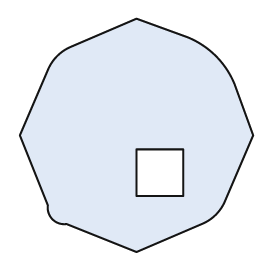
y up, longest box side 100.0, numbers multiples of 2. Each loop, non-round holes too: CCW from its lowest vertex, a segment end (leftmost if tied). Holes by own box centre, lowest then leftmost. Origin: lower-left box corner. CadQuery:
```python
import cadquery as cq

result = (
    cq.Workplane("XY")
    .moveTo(50.0, 0.0)
    .lineTo(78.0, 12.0)
    .threePointArc((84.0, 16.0), (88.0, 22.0))
    .lineTo(100.0, 50.0)
    .lineTo(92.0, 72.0)
    .threePointArc((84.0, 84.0), (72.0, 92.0))
    .lineTo(50.0, 100.0)
    .lineTo(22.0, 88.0)
    .threePointArc((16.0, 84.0), (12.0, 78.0))
    .lineTo(0.0, 50.0)
    .lineTo(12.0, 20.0)
    .threePointArc((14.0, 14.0), (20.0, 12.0))
    .close()
    .moveTo(50.0, 24.0)
    .lineTo(70.0, 24.0)
    .lineTo(70.0, 44.0)
    .lineTo(50.0, 44.0)
    .close()
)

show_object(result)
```